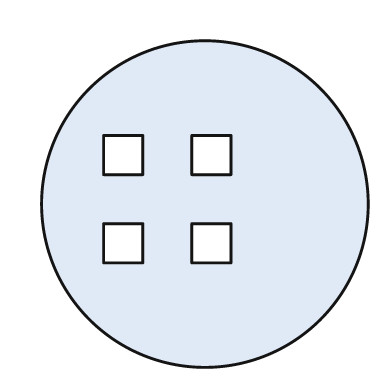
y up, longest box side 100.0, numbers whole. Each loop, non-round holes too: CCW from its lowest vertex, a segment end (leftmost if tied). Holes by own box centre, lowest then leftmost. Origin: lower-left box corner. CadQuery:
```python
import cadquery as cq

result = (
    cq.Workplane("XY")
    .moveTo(50.0, 50.0)
    .circle(50.0)
    .moveTo(19.0, 32.0)
    .lineTo(31.0, 32.0)
    .lineTo(31.0, 44.0)
    .lineTo(19.0, 44.0)
    .close()
    .moveTo(46.0, 32.0)
    .lineTo(58.0, 32.0)
    .lineTo(58.0, 44.0)
    .lineTo(46.0, 44.0)
    .close()
    .moveTo(19.0, 59.0)
    .lineTo(31.0, 59.0)
    .lineTo(31.0, 71.0)
    .lineTo(19.0, 71.0)
    .close()
    .moveTo(46.0, 59.0)
    .lineTo(58.0, 59.0)
    .lineTo(58.0, 71.0)
    .lineTo(46.0, 71.0)
    .close()
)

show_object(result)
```